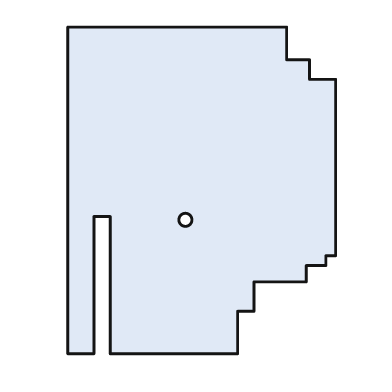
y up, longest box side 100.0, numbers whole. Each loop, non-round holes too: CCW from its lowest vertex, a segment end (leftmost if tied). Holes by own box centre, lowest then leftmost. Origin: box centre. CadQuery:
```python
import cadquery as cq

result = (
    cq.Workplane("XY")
    .moveTo(-41.0, -50.0)
    .lineTo(-33.0, -50.0)
    .lineTo(-33.0, -8.0)
    .lineTo(-28.0, -8.0)
    .lineTo(-28.0, -50.0)
    .lineTo(11.0, -50.0)
    .lineTo(11.0, -37.0)
    .lineTo(16.0, -37.0)
    .lineTo(16.0, -28.0)
    .lineTo(32.0, -28.0)
    .lineTo(32.0, -23.0)
    .lineTo(38.0, -23.0)
    .lineTo(38.0, -20.0)
    .lineTo(41.0, -20.0)
    .lineTo(41.0, 34.0)
    .lineTo(33.0, 34.0)
    .lineTo(33.0, 40.0)
    .lineTo(26.0, 40.0)
    .lineTo(26.0, 50.0)
    .lineTo(-41.0, 50.0)
    .close()
    .moveTo(-5.0, -9.0)
    .circle(2.0)
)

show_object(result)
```